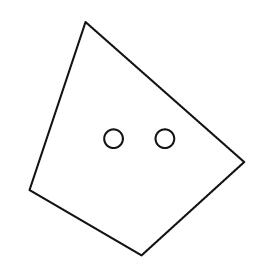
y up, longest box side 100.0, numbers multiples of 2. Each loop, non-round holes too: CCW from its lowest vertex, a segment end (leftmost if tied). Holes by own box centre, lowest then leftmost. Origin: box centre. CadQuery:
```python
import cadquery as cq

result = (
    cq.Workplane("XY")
    .moveTo(2.0, -50.0)
    .lineTo(46.0, -10.0)
    .lineTo(-22.0, 50.0)
    .lineTo(-46.0, -22.0)
    .close()
    .moveTo(-10.0, 0.0)
    .circle(4.0)
    .moveTo(12.0, 0.0)
    .circle(4.0)
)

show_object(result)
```